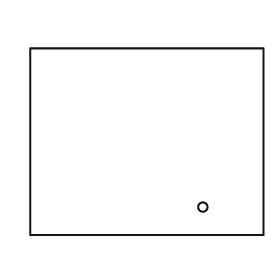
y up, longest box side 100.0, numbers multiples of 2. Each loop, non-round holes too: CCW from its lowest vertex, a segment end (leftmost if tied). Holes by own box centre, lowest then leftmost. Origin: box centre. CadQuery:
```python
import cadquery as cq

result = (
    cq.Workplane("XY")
    .moveTo(-50.0, -40.0)
    .lineTo(50.0, -40.0)
    .lineTo(50.0, 40.0)
    .lineTo(-50.0, 40.0)
    .close()
    .moveTo(24.0, -28.0)
    .circle(2.0)
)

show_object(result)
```